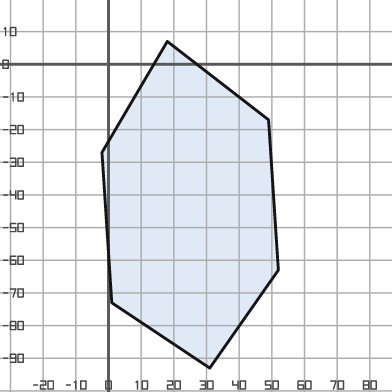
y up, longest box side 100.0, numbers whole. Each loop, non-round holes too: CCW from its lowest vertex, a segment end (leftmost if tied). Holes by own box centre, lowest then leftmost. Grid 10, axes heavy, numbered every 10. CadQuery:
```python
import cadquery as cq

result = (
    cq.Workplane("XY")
    .moveTo(31.0, -93.0)
    .lineTo(52.0, -63.0)
    .lineTo(49.0, -17.0)
    .lineTo(18.0, 7.0)
    .lineTo(-2.0, -27.0)
    .lineTo(1.0, -73.0)
    .close()
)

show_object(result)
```